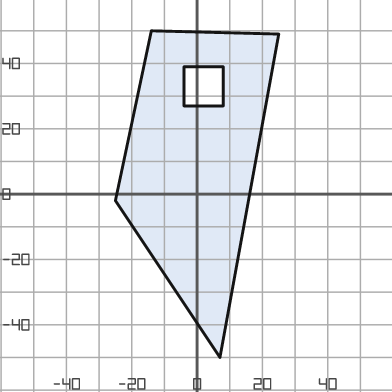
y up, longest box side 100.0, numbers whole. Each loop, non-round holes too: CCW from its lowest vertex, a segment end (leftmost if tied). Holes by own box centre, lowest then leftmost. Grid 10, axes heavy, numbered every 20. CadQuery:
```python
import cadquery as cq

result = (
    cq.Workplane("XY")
    .moveTo(7.0, -50.0)
    .lineTo(25.0, 49.0)
    .lineTo(-14.0, 50.0)
    .lineTo(-25.0, -2.0)
    .close()
    .moveTo(-4.0, 27.0)
    .lineTo(8.0, 27.0)
    .lineTo(8.0, 39.0)
    .lineTo(-4.0, 39.0)
    .close()
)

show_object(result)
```